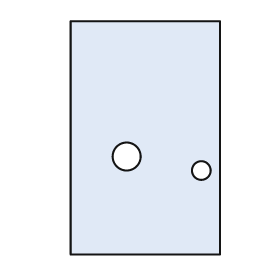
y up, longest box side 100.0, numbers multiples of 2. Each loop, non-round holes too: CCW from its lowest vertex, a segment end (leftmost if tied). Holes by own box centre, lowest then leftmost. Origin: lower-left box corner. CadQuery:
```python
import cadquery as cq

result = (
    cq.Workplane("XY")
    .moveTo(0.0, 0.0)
    .lineTo(64.0, 0.0)
    .lineTo(64.0, 100.0)
    .lineTo(0.0, 100.0)
    .close()
    .moveTo(56.0, 36.0)
    .circle(4.0)
    .moveTo(24.0, 42.0)
    .circle(6.0)
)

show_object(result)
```